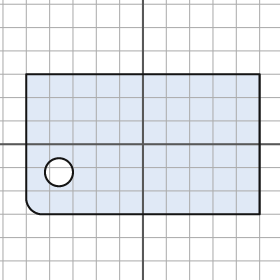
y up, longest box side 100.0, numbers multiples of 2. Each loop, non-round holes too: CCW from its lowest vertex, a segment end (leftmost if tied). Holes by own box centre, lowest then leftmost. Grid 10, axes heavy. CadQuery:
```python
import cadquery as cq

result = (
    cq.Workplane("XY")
    .moveTo(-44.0, -30.0)
    .lineTo(50.0, -30.0)
    .lineTo(50.0, 30.0)
    .lineTo(-50.0, 30.0)
    .lineTo(-50.0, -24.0)
    .threePointArc((-48.0, -28.0), (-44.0, -30.0))
    .close()
    .moveTo(-36.0, -12.0)
    .circle(6.0)
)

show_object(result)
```